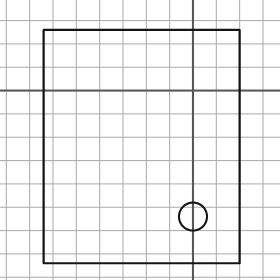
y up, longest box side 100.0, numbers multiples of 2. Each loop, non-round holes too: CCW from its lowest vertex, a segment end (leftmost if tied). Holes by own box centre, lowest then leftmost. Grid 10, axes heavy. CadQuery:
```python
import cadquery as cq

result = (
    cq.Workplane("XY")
    .moveTo(-64.0, -74.0)
    .lineTo(20.0, -74.0)
    .lineTo(20.0, 26.0)
    .lineTo(-64.0, 26.0)
    .close()
    .moveTo(0.0, -54.0)
    .circle(6.0)
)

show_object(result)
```